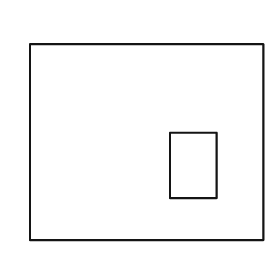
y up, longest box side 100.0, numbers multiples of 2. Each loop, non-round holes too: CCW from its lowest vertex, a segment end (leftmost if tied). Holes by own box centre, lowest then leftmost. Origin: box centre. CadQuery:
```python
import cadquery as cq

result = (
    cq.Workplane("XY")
    .moveTo(-50.0, -42.0)
    .lineTo(50.0, -42.0)
    .lineTo(50.0, 42.0)
    .lineTo(-50.0, 42.0)
    .close()
    .moveTo(10.0, -24.0)
    .lineTo(30.0, -24.0)
    .lineTo(30.0, 4.0)
    .lineTo(10.0, 4.0)
    .close()
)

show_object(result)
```